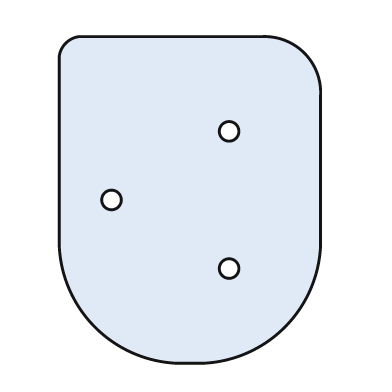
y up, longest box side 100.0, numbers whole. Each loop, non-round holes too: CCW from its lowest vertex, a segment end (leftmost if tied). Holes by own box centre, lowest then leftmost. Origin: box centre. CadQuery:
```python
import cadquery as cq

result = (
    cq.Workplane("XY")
    .moveTo(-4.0, -50.0)
    .lineTo(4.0, -50.0)
    .threePointArc((29.0, -39.0), (40.0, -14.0))
    .lineTo(40.0, 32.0)
    .threePointArc((35.0, 45.0), (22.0, 50.0))
    .lineTo(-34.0, 50.0)
    .threePointArc((-38.0, 48.0), (-40.0, 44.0))
    .lineTo(-40.0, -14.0)
    .threePointArc((-29.0, -39.0), (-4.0, -50.0))
    .close()
    .moveTo(12.0, -21.0)
    .circle(3.0)
    .moveTo(-24.0, 0.0)
    .circle(3.0)
    .moveTo(12.0, 21.0)
    .circle(3.0)
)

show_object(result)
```